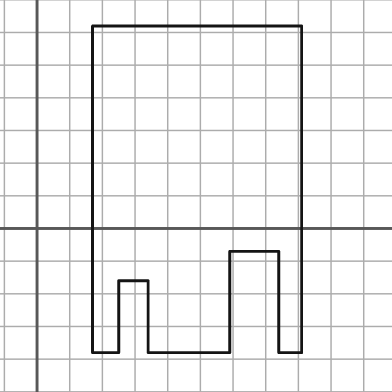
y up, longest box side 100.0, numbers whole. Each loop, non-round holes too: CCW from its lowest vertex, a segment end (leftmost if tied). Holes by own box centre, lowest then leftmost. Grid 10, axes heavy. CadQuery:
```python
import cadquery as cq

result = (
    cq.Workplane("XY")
    .moveTo(17.0, -38.0)
    .lineTo(25.0, -38.0)
    .lineTo(25.0, -16.0)
    .lineTo(34.0, -16.0)
    .lineTo(34.0, -38.0)
    .lineTo(59.0, -38.0)
    .lineTo(59.0, -7.0)
    .lineTo(74.0, -7.0)
    .lineTo(74.0, -38.0)
    .lineTo(81.0, -38.0)
    .lineTo(81.0, 62.0)
    .lineTo(17.0, 62.0)
    .close()
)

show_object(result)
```